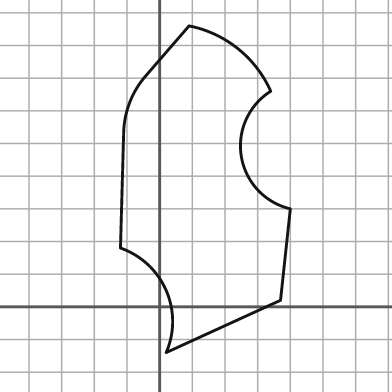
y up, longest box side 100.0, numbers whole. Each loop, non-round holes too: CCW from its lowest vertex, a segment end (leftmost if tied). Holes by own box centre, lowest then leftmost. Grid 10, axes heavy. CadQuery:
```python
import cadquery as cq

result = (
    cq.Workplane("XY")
    .moveTo(2.0, -14.0)
    .lineTo(37.0, 2.0)
    .lineTo(40.0, 30.0)
    .threePointArc((25.0, 46.0), (34.0, 66.0))
    .threePointArc((24.0, 79.0), (9.0, 86.0))
    .lineTo(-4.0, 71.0)
    .threePointArc((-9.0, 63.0), (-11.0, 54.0))
    .lineTo(-12.0, 18.0)
    .threePointArc((2.0, 5.0), (2.0, -14.0))
    .close()
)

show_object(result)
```